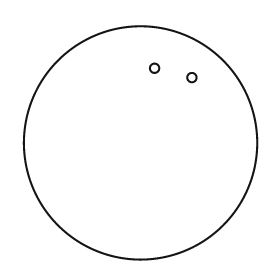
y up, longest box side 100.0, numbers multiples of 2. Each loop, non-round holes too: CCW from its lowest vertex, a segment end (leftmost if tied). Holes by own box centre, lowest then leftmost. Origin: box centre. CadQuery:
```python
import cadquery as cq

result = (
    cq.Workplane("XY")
    .moveTo(0.0, 0.0)
    .circle(50.0)
    .moveTo(22.0, 28.0)
    .circle(2.0)
    .moveTo(6.0, 32.0)
    .circle(2.0)
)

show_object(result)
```